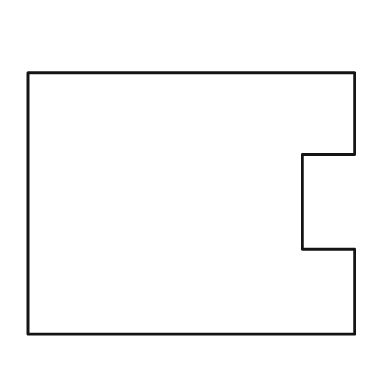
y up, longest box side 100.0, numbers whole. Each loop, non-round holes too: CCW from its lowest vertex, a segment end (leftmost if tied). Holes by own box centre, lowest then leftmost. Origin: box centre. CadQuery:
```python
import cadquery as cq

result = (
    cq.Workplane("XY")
    .moveTo(-50.0, -40.0)
    .lineTo(50.0, -40.0)
    .lineTo(50.0, -14.0)
    .lineTo(34.0, -14.0)
    .lineTo(34.0, 15.0)
    .lineTo(50.0, 15.0)
    .lineTo(50.0, 40.0)
    .lineTo(-50.0, 40.0)
    .close()
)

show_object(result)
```